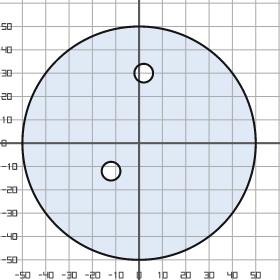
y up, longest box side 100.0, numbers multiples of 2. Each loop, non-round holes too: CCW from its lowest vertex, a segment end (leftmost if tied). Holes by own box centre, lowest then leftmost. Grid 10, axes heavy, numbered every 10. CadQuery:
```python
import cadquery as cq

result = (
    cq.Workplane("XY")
    .moveTo(0.0, 0.0)
    .circle(50.0)
    .moveTo(-12.0, -12.0)
    .circle(4.0)
    .moveTo(2.0, 30.0)
    .circle(4.0)
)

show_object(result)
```